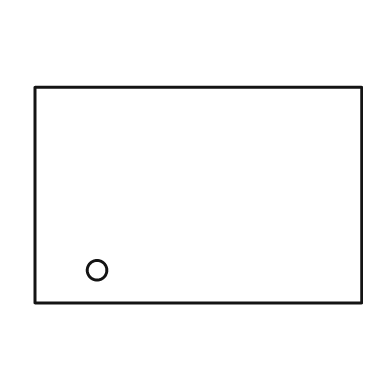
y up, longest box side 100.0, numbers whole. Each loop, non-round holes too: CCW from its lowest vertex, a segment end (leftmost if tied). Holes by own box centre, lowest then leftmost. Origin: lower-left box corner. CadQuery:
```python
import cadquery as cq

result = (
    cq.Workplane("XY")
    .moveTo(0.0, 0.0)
    .lineTo(100.0, 0.0)
    .lineTo(100.0, 66.0)
    .lineTo(0.0, 66.0)
    .close()
    .moveTo(19.0, 10.0)
    .circle(3.0)
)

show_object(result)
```